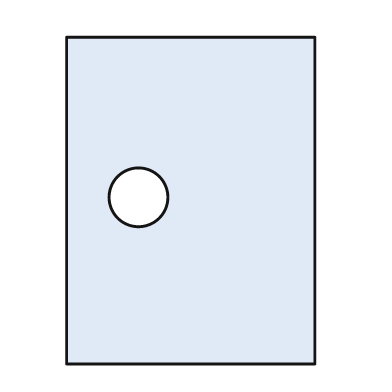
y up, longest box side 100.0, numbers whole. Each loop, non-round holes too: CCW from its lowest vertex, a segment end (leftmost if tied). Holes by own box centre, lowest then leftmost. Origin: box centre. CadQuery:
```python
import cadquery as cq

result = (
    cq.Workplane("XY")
    .moveTo(-38.0, -50.0)
    .lineTo(38.0, -50.0)
    .lineTo(38.0, 50.0)
    .lineTo(-38.0, 50.0)
    .close()
    .moveTo(-16.0, 1.0)
    .circle(9.0)
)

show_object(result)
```